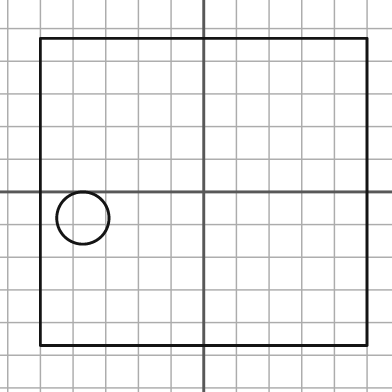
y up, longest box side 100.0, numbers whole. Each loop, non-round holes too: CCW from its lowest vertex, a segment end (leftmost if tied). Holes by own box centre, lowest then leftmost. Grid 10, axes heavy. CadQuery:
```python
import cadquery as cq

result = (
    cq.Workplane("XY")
    .moveTo(-50.0, -47.0)
    .lineTo(50.0, -47.0)
    .lineTo(50.0, 47.0)
    .lineTo(-50.0, 47.0)
    .close()
    .moveTo(-37.0, -8.0)
    .circle(8.0)
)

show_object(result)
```